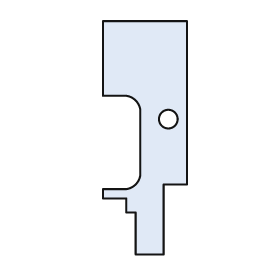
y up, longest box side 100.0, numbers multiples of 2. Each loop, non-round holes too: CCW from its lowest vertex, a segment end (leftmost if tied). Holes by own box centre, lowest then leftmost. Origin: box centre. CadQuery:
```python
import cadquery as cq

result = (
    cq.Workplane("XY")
    .moveTo(-4.0, -50.0)
    .lineTo(8.0, -50.0)
    .lineTo(8.0, -20.0)
    .lineTo(18.0, -20.0)
    .lineTo(18.0, 50.0)
    .lineTo(-18.0, 50.0)
    .lineTo(-18.0, 18.0)
    .lineTo(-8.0, 18.0)
    .threePointArc((-4.0, 16.0), (-2.0, 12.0))
    .lineTo(-2.0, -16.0)
    .threePointArc((-4.0, -20.0), (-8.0, -22.0))
    .lineTo(-18.0, -22.0)
    .lineTo(-18.0, -26.0)
    .lineTo(-8.0, -26.0)
    .lineTo(-8.0, -32.0)
    .lineTo(-4.0, -32.0)
    .close()
    .moveTo(10.0, 8.0)
    .circle(4.0)
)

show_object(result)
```